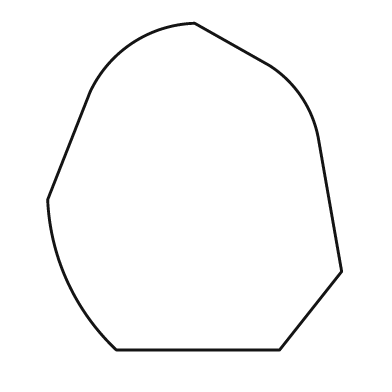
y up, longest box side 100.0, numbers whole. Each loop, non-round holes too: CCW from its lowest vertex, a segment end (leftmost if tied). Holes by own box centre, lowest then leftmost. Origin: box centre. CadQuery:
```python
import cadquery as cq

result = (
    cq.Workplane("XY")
    .moveTo(-24.0, -50.0)
    .lineTo(26.0, -50.0)
    .lineTo(45.0, -26.0)
    .lineTo(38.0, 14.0)
    .threePointArc((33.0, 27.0), (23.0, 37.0))
    .lineTo(0.0, 50.0)
    .threePointArc((-19.0, 44.0), (-32.0, 29.0))
    .lineTo(-45.0, -4.0)
    .threePointArc((-39.0, -29.0), (-24.0, -50.0))
    .close()
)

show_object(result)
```